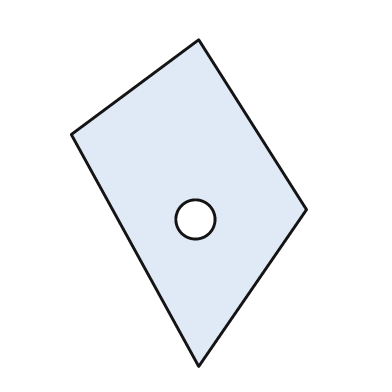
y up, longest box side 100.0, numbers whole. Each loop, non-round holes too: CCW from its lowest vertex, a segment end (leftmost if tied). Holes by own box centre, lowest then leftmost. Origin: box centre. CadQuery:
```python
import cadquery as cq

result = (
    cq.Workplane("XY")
    .moveTo(3.0, -50.0)
    .lineTo(36.0, -2.0)
    .lineTo(3.0, 50.0)
    .lineTo(-36.0, 21.0)
    .close()
    .moveTo(2.0, -5.0)
    .circle(6.0)
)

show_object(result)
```